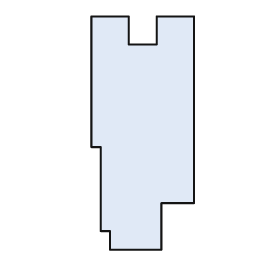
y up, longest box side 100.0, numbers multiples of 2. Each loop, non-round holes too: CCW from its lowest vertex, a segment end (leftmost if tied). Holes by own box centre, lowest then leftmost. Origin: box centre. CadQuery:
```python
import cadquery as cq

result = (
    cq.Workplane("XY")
    .moveTo(-14.0, -50.0)
    .lineTo(8.0, -50.0)
    .lineTo(8.0, -30.0)
    .lineTo(22.0, -30.0)
    .lineTo(22.0, 50.0)
    .lineTo(6.0, 50.0)
    .lineTo(6.0, 38.0)
    .lineTo(-6.0, 38.0)
    .lineTo(-6.0, 50.0)
    .lineTo(-22.0, 50.0)
    .lineTo(-22.0, -6.0)
    .lineTo(-18.0, -6.0)
    .lineTo(-18.0, -42.0)
    .lineTo(-14.0, -42.0)
    .close()
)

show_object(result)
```